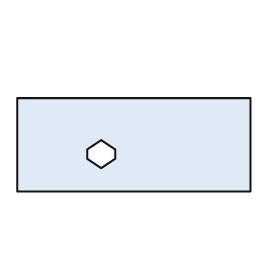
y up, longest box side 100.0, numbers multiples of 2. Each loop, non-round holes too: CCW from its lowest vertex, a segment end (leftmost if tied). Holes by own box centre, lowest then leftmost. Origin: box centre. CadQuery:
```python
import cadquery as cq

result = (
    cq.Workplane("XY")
    .moveTo(-50.0, -20.0)
    .lineTo(50.0, -20.0)
    .lineTo(50.0, 20.0)
    .lineTo(-50.0, 20.0)
    .close()
    .moveTo(-14.0, -10.0)
    .lineTo(-8.0, -6.0)
    .lineTo(-8.0, -2.0)
    .lineTo(-14.0, 2.0)
    .lineTo(-20.0, -2.0)
    .lineTo(-20.0, -6.0)
    .close()
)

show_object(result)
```